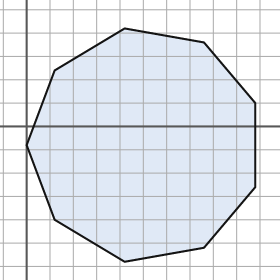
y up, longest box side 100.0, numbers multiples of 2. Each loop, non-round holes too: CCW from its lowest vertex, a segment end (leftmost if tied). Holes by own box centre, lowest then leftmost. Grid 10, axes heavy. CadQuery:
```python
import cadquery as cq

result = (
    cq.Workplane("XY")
    .moveTo(42.0, -58.0)
    .lineTo(76.0, -52.0)
    .lineTo(98.0, -26.0)
    .lineTo(98.0, 10.0)
    .lineTo(76.0, 36.0)
    .lineTo(42.0, 42.0)
    .lineTo(12.0, 24.0)
    .lineTo(0.0, -8.0)
    .lineTo(12.0, -40.0)
    .close()
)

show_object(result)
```